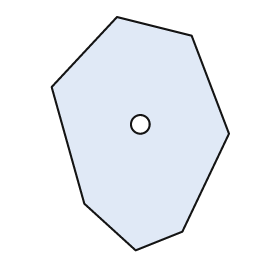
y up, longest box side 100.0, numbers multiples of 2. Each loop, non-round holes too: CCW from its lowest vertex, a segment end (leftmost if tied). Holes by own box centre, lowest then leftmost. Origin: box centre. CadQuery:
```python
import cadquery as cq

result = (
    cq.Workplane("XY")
    .moveTo(-2.0, -50.0)
    .lineTo(18.0, -42.0)
    .lineTo(38.0, 0.0)
    .lineTo(22.0, 42.0)
    .lineTo(-10.0, 50.0)
    .lineTo(-38.0, 20.0)
    .lineTo(-24.0, -30.0)
    .close()
    .moveTo(0.0, 4.0)
    .circle(4.0)
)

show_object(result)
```